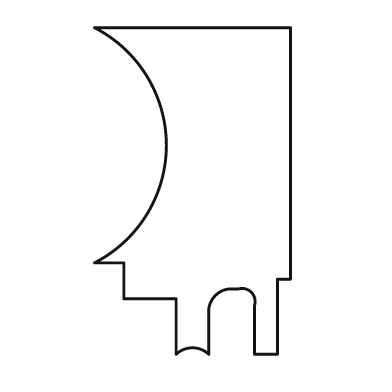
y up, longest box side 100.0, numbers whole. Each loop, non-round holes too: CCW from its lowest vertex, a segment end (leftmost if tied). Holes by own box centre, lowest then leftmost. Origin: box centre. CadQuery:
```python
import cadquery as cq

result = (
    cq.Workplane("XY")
    .moveTo(-5.0, -50.0)
    .threePointArc((0.0, -48.0), (5.0, -50.0))
    .lineTo(5.0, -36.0)
    .threePointArc((7.0, -32.0), (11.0, -30.0))
    .lineTo(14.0, -30.0)
    .threePointArc((18.0, -31.0), (19.0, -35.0))
    .lineTo(19.0, -50.0)
    .lineTo(26.0, -50.0)
    .lineTo(26.0, -27.0)
    .lineTo(30.0, -27.0)
    .lineTo(30.0, 50.0)
    .lineTo(-30.0, 50.0)
    .threePointArc((-8.0, 14.0), (-30.0, -22.0))
    .lineTo(-21.0, -22.0)
    .lineTo(-21.0, -33.0)
    .lineTo(-5.0, -33.0)
    .close()
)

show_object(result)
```